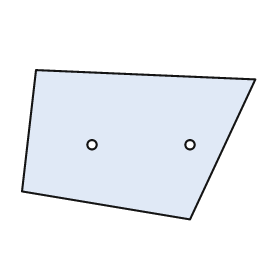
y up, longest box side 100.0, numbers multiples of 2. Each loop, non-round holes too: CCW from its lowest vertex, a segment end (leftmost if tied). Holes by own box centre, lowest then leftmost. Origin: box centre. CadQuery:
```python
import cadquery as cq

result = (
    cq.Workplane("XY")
    .moveTo(22.0, -32.0)
    .lineTo(50.0, 28.0)
    .lineTo(-44.0, 32.0)
    .lineTo(-50.0, -20.0)
    .close()
    .moveTo(-20.0, 0.0)
    .circle(2.0)
    .moveTo(22.0, 0.0)
    .circle(2.0)
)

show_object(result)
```